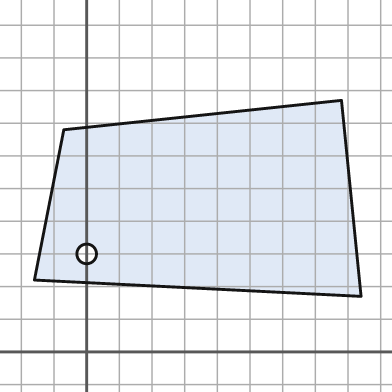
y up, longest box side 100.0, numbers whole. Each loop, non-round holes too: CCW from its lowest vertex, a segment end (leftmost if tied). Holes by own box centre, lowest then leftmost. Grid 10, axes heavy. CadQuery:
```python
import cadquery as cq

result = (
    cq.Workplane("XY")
    .moveTo(84.0, 17.0)
    .lineTo(78.0, 77.0)
    .lineTo(-7.0, 68.0)
    .lineTo(-16.0, 22.0)
    .close()
    .moveTo(0.0, 30.0)
    .circle(3.0)
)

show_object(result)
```